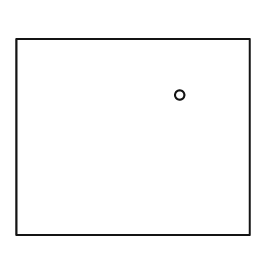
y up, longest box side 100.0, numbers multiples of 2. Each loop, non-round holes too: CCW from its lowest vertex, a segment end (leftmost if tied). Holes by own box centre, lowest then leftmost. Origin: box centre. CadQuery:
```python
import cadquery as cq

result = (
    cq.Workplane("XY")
    .moveTo(-50.0, -42.0)
    .lineTo(50.0, -42.0)
    .lineTo(50.0, 42.0)
    .lineTo(-50.0, 42.0)
    .close()
    .moveTo(20.0, 18.0)
    .circle(2.0)
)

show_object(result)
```